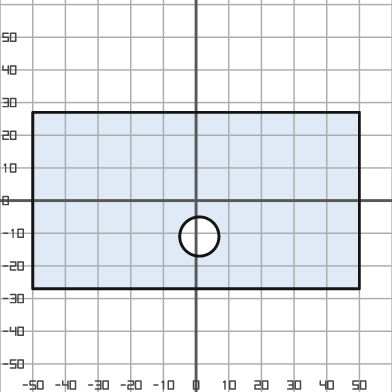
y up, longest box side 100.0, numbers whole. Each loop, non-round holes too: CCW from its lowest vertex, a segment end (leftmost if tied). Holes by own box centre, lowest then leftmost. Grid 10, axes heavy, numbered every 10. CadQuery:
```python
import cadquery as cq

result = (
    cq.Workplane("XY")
    .moveTo(-50.0, -27.0)
    .lineTo(50.0, -27.0)
    .lineTo(50.0, 27.0)
    .lineTo(-50.0, 27.0)
    .close()
    .moveTo(1.0, -11.0)
    .circle(6.0)
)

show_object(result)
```